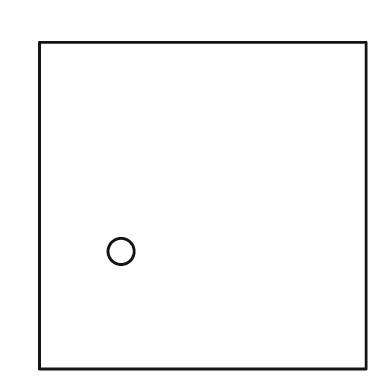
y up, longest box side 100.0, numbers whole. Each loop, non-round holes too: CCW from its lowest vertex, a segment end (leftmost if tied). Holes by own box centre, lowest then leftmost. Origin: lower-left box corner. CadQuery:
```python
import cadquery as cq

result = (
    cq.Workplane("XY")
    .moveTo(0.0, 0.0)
    .lineTo(100.0, 0.0)
    .lineTo(100.0, 100.0)
    .lineTo(0.0, 100.0)
    .close()
    .moveTo(25.0, 36.0)
    .circle(4.0)
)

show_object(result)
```